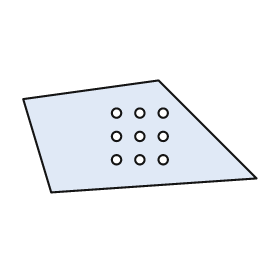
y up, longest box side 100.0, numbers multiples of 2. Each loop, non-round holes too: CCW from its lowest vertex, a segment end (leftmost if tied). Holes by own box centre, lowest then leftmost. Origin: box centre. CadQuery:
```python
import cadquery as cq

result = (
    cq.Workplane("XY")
    .moveTo(-38.0, -24.0)
    .lineTo(50.0, -18.0)
    .lineTo(8.0, 24.0)
    .lineTo(-50.0, 16.0)
    .close()
    .moveTo(-10.0, -10.0)
    .circle(2.0)
    .moveTo(0.0, -10.0)
    .circle(2.0)
    .moveTo(10.0, -10.0)
    .circle(2.0)
    .moveTo(-10.0, 0.0)
    .circle(2.0)
    .moveTo(0.0, 0.0)
    .circle(2.0)
    .moveTo(10.0, 0.0)
    .circle(2.0)
    .moveTo(-10.0, 10.0)
    .circle(2.0)
    .moveTo(0.0, 10.0)
    .circle(2.0)
    .moveTo(10.0, 10.0)
    .circle(2.0)
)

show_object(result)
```